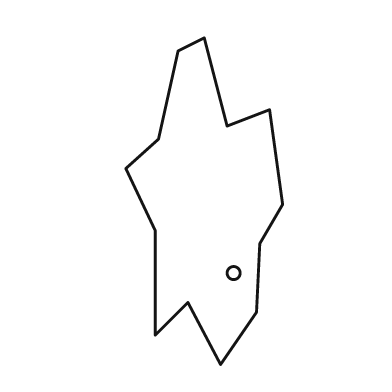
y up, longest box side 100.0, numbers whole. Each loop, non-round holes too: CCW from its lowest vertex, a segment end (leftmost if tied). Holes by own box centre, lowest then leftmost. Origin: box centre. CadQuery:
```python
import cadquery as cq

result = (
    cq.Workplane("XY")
    .moveTo(5.0, -50.0)
    .lineTo(16.0, -34.0)
    .lineTo(17.0, -13.0)
    .lineTo(24.0, -1.0)
    .lineTo(20.0, 28.0)
    .lineTo(7.0, 23.0)
    .lineTo(0.0, 50.0)
    .lineTo(-8.0, 46.0)
    .lineTo(-14.0, 19.0)
    .lineTo(-24.0, 10.0)
    .lineTo(-15.0, -9.0)
    .lineTo(-15.0, -41.0)
    .lineTo(-5.0, -31.0)
    .close()
    .moveTo(9.0, -22.0)
    .circle(2.0)
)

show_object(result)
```